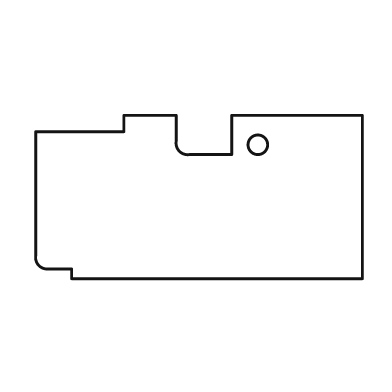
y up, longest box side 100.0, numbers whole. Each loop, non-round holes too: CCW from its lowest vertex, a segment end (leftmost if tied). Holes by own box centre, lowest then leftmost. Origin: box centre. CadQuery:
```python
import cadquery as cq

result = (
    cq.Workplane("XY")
    .moveTo(-39.0, -25.0)
    .lineTo(50.0, -25.0)
    .lineTo(50.0, 25.0)
    .lineTo(10.0, 25.0)
    .lineTo(10.0, 13.0)
    .lineTo(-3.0, 13.0)
    .threePointArc((-6.0, 14.0), (-7.0, 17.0))
    .lineTo(-7.0, 25.0)
    .lineTo(-23.0, 25.0)
    .lineTo(-23.0, 20.0)
    .lineTo(-50.0, 20.0)
    .lineTo(-50.0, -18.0)
    .threePointArc((-49.0, -21.0), (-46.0, -22.0))
    .lineTo(-39.0, -22.0)
    .close()
    .moveTo(18.0, 16.0)
    .circle(3.0)
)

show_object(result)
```